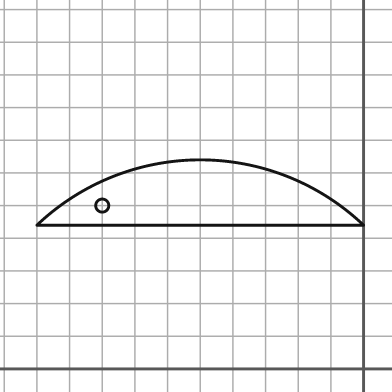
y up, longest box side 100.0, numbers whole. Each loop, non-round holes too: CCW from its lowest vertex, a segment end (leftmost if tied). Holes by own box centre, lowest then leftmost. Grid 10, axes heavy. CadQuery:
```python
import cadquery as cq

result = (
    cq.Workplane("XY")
    .moveTo(-100.0, 44.0)
    .lineTo(0.0, 44.0)
    .threePointArc((-50.0, 64.0), (-100.0, 44.0))
    .close()
    .moveTo(-80.0, 50.0)
    .circle(2.0)
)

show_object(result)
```